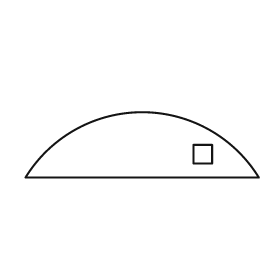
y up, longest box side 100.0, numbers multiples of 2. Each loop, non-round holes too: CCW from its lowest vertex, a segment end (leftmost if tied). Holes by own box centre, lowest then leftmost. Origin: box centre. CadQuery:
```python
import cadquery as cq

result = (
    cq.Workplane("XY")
    .moveTo(-50.0, -14.0)
    .lineTo(50.0, -14.0)
    .threePointArc((0.0, 14.0), (-50.0, -14.0))
    .close()
    .moveTo(22.0, -8.0)
    .lineTo(30.0, -8.0)
    .lineTo(30.0, 0.0)
    .lineTo(22.0, 0.0)
    .close()
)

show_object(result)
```